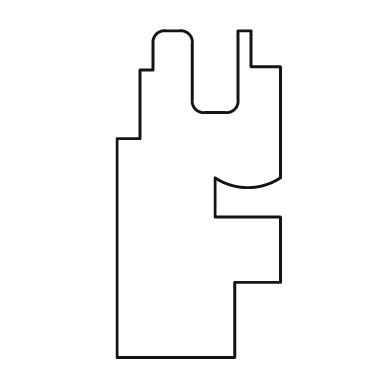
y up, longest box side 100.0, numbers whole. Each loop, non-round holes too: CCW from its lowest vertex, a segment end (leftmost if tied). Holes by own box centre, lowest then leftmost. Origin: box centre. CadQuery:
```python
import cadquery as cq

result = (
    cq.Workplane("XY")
    .moveTo(-25.0, -50.0)
    .lineTo(11.0, -50.0)
    .lineTo(11.0, -27.0)
    .lineTo(25.0, -27.0)
    .lineTo(25.0, -7.0)
    .lineTo(5.0, -7.0)
    .lineTo(5.0, 5.0)
    .threePointArc((15.0, 2.0), (25.0, 5.0))
    .lineTo(25.0, 39.0)
    .lineTo(16.0, 39.0)
    .lineTo(16.0, 50.0)
    .lineTo(12.0, 50.0)
    .lineTo(12.0, 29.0)
    .threePointArc((11.0, 26.0), (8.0, 25.0))
    .lineTo(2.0, 25.0)
    .threePointArc((-1.0, 26.0), (-2.0, 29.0))
    .lineTo(-2.0, 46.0)
    .threePointArc((-3.0, 49.0), (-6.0, 50.0))
    .lineTo(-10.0, 50.0)
    .threePointArc((-13.0, 49.0), (-14.0, 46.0))
    .lineTo(-14.0, 38.0)
    .lineTo(-18.0, 38.0)
    .lineTo(-18.0, 17.0)
    .lineTo(-25.0, 17.0)
    .close()
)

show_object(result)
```